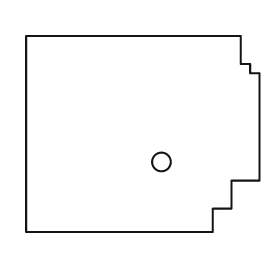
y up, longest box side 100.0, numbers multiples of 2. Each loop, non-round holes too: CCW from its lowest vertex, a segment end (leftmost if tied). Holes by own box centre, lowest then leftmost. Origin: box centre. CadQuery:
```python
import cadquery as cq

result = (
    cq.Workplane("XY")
    .moveTo(-50.0, -42.0)
    .lineTo(30.0, -42.0)
    .lineTo(30.0, -32.0)
    .lineTo(38.0, -32.0)
    .lineTo(38.0, -20.0)
    .lineTo(50.0, -20.0)
    .lineTo(50.0, 26.0)
    .lineTo(46.0, 26.0)
    .lineTo(46.0, 30.0)
    .lineTo(42.0, 30.0)
    .lineTo(42.0, 42.0)
    .lineTo(-50.0, 42.0)
    .close()
    .moveTo(8.0, -12.0)
    .circle(4.0)
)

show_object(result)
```